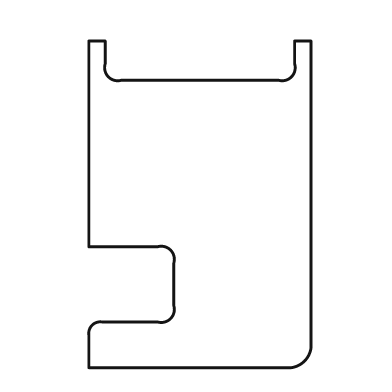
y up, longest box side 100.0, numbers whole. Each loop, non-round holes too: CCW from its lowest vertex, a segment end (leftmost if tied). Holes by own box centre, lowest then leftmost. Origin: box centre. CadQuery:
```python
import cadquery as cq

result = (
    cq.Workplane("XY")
    .moveTo(-34.0, -50.0)
    .lineTo(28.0, -50.0)
    .threePointArc((32.0, -48.0), (34.0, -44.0))
    .lineTo(34.0, 50.0)
    .lineTo(29.0, 50.0)
    .lineTo(29.0, 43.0)
    .threePointArc((28.0, 39.0), (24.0, 38.0))
    .lineTo(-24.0, 38.0)
    .threePointArc((-28.0, 39.0), (-29.0, 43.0))
    .lineTo(-29.0, 50.0)
    .lineTo(-34.0, 50.0)
    .lineTo(-34.0, -13.0)
    .lineTo(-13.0, -13.0)
    .threePointArc((-9.0, -14.0), (-8.0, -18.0))
    .lineTo(-8.0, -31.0)
    .threePointArc((-9.0, -35.0), (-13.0, -36.0))
    .lineTo(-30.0, -36.0)
    .threePointArc((-33.0, -37.0), (-34.0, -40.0))
    .close()
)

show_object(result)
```